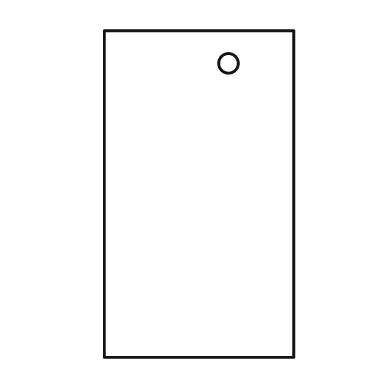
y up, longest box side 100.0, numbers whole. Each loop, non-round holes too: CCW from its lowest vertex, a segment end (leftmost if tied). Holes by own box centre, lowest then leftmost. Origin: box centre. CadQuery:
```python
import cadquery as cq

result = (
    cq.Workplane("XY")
    .moveTo(-29.0, -50.0)
    .lineTo(29.0, -50.0)
    .lineTo(29.0, 50.0)
    .lineTo(-29.0, 50.0)
    .close()
    .moveTo(9.0, 40.0)
    .circle(3.0)
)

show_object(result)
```